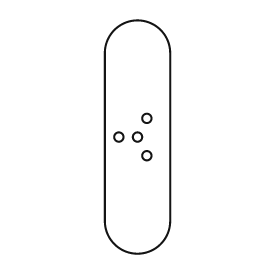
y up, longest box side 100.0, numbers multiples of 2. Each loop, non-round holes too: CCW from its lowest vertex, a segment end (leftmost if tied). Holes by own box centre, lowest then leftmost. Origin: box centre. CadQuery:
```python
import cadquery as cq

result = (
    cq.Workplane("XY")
    .moveTo(-14.0, -36.0)
    .threePointArc((0.0, -50.0), (14.0, -36.0))
    .lineTo(14.0, 36.0)
    .threePointArc((0.0, 50.0), (-14.0, 36.0))
    .close()
    .moveTo(4.0, -8.0)
    .circle(2.0)
    .moveTo(-8.0, 0.0)
    .circle(2.0)
    .moveTo(0.0, 0.0)
    .circle(2.0)
    .moveTo(4.0, 8.0)
    .circle(2.0)
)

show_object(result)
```